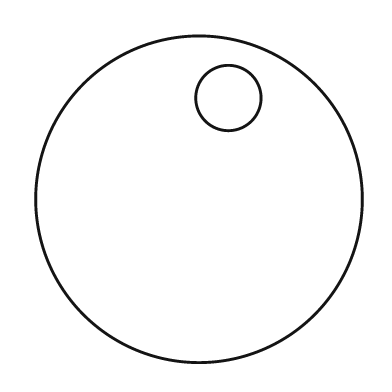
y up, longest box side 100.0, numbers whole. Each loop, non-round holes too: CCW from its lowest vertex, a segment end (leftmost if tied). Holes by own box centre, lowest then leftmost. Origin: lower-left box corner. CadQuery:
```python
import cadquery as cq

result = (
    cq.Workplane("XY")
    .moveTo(50.0, 50.0)
    .circle(50.0)
    .moveTo(59.0, 81.0)
    .circle(10.0)
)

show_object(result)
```